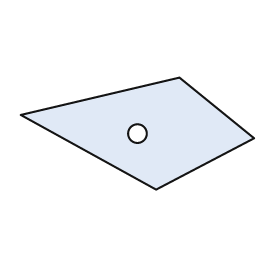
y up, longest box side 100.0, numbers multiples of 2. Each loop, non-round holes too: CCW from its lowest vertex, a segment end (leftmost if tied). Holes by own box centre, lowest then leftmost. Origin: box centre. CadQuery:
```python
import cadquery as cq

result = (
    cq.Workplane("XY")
    .moveTo(8.0, -24.0)
    .lineTo(50.0, -2.0)
    .lineTo(18.0, 24.0)
    .lineTo(-50.0, 8.0)
    .close()
    .moveTo(0.0, 0.0)
    .circle(4.0)
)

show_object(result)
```